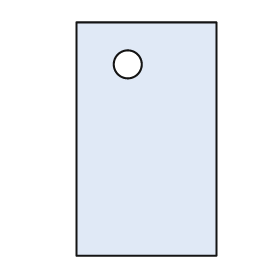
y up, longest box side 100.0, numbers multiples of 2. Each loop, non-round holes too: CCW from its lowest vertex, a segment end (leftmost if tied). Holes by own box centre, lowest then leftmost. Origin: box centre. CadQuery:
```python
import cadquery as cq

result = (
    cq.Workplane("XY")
    .moveTo(-30.0, -50.0)
    .lineTo(30.0, -50.0)
    .lineTo(30.0, 50.0)
    .lineTo(-30.0, 50.0)
    .close()
    .moveTo(-8.0, 32.0)
    .circle(6.0)
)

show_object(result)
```